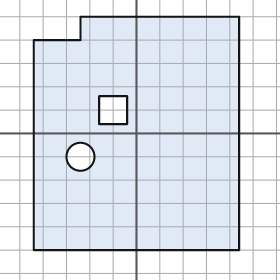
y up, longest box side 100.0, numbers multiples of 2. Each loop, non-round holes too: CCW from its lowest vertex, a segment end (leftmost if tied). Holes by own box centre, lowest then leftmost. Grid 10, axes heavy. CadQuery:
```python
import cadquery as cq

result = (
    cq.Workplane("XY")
    .moveTo(-44.0, -50.0)
    .lineTo(44.0, -50.0)
    .lineTo(44.0, 50.0)
    .lineTo(-24.0, 50.0)
    .lineTo(-24.0, 40.0)
    .lineTo(-44.0, 40.0)
    .close()
    .moveTo(-24.0, -10.0)
    .circle(6.0)
    .moveTo(-16.0, 4.0)
    .lineTo(-4.0, 4.0)
    .lineTo(-4.0, 16.0)
    .lineTo(-16.0, 16.0)
    .close()
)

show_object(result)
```